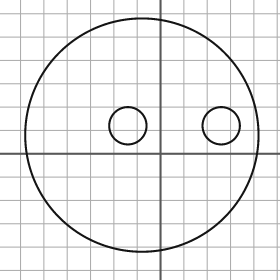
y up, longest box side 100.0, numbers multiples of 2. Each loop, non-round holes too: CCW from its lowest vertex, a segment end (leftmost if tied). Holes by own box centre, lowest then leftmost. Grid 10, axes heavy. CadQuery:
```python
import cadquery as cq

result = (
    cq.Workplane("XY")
    .moveTo(-8.0, 8.0)
    .circle(50.0)
    .moveTo(-14.0, 12.0)
    .circle(8.0)
    .moveTo(26.0, 12.0)
    .circle(8.0)
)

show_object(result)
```